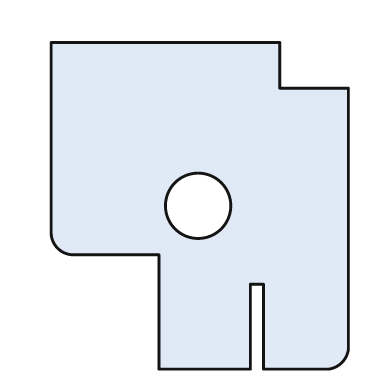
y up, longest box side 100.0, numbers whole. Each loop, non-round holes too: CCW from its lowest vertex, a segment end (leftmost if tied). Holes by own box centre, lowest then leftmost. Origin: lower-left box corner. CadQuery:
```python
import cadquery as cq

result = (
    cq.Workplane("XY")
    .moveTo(33.0, 0.0)
    .lineTo(61.0, 0.0)
    .lineTo(61.0, 26.0)
    .lineTo(65.0, 26.0)
    .lineTo(65.0, 0.0)
    .lineTo(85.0, 0.0)
    .threePointArc((89.0, 2.0), (91.0, 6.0))
    .lineTo(91.0, 86.0)
    .lineTo(70.0, 86.0)
    .lineTo(70.0, 100.0)
    .lineTo(0.0, 100.0)
    .lineTo(0.0, 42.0)
    .threePointArc((2.0, 37.0), (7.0, 35.0))
    .lineTo(33.0, 35.0)
    .close()
    .moveTo(45.0, 50.0)
    .circle(10.0)
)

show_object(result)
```